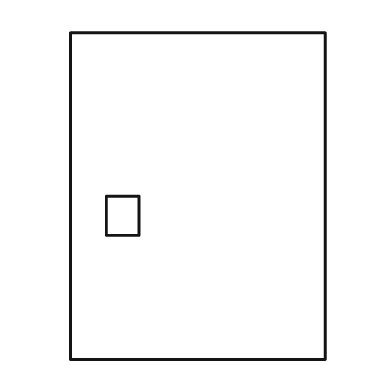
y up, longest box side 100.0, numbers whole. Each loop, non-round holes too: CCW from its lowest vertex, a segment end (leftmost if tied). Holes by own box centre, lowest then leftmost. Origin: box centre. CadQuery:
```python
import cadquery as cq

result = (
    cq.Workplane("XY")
    .moveTo(-39.0, -50.0)
    .lineTo(39.0, -50.0)
    .lineTo(39.0, 50.0)
    .lineTo(-39.0, 50.0)
    .close()
    .moveTo(-28.0, -12.0)
    .lineTo(-18.0, -12.0)
    .lineTo(-18.0, 0.0)
    .lineTo(-28.0, 0.0)
    .close()
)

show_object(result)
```